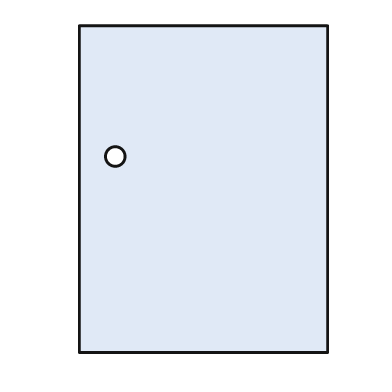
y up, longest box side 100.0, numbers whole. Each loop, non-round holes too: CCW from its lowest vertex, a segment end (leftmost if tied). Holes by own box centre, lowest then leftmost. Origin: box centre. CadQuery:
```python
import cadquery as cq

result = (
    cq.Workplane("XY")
    .moveTo(-38.0, -50.0)
    .lineTo(38.0, -50.0)
    .lineTo(38.0, 50.0)
    .lineTo(-38.0, 50.0)
    .close()
    .moveTo(-27.0, 10.0)
    .circle(3.0)
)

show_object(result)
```